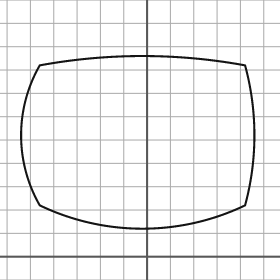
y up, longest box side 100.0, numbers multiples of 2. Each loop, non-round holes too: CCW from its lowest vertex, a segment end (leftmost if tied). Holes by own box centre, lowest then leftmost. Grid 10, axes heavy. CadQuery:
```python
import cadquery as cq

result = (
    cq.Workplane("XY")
    .moveTo(-46.0, 22.0)
    .threePointArc((-2.0, 12.0), (42.0, 22.0))
    .threePointArc((46.0, 52.0), (42.0, 82.0))
    .threePointArc((-2.0, 86.0), (-46.0, 82.0))
    .threePointArc((-54.0, 52.0), (-46.0, 22.0))
    .close()
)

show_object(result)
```